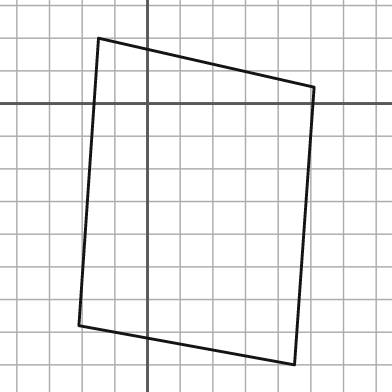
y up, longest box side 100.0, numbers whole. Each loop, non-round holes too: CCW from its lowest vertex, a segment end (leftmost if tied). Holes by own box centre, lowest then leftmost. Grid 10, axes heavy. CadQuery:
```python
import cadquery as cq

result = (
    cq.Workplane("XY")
    .moveTo(45.0, -80.0)
    .lineTo(51.0, 5.0)
    .lineTo(-15.0, 20.0)
    .lineTo(-21.0, -68.0)
    .close()
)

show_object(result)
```